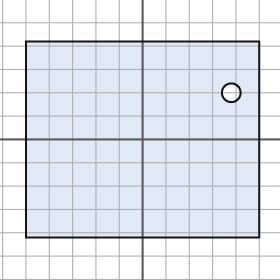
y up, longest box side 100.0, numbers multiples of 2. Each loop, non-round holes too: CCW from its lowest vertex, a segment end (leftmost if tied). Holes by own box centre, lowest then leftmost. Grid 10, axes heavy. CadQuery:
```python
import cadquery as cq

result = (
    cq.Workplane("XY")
    .moveTo(-50.0, -42.0)
    .lineTo(50.0, -42.0)
    .lineTo(50.0, 42.0)
    .lineTo(-50.0, 42.0)
    .close()
    .moveTo(38.0, 20.0)
    .circle(4.0)
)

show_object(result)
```